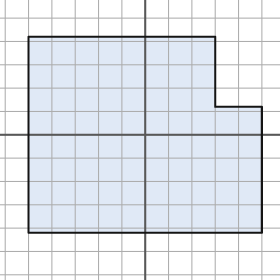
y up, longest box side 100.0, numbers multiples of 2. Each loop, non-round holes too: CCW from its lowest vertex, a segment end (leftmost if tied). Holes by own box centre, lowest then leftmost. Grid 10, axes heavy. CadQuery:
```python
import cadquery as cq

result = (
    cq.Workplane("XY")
    .moveTo(-50.0, -42.0)
    .lineTo(50.0, -42.0)
    .lineTo(50.0, 12.0)
    .lineTo(30.0, 12.0)
    .lineTo(30.0, 42.0)
    .lineTo(-50.0, 42.0)
    .close()
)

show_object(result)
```